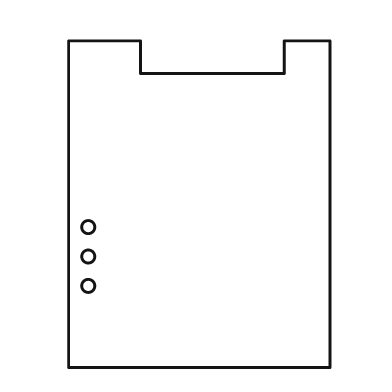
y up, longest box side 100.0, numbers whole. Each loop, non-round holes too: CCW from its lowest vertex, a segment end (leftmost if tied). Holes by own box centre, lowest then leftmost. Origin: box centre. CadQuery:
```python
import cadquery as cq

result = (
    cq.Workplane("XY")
    .moveTo(-40.0, -50.0)
    .lineTo(40.0, -50.0)
    .lineTo(40.0, 50.0)
    .lineTo(26.0, 50.0)
    .lineTo(26.0, 40.0)
    .lineTo(-18.0, 40.0)
    .lineTo(-18.0, 50.0)
    .lineTo(-40.0, 50.0)
    .close()
    .moveTo(-34.0, -25.0)
    .circle(2.0)
    .moveTo(-34.0, -16.0)
    .circle(2.0)
    .moveTo(-34.0, -7.0)
    .circle(2.0)
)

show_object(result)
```